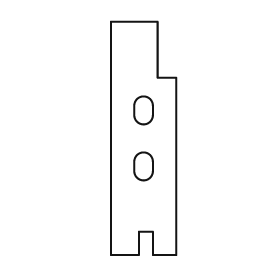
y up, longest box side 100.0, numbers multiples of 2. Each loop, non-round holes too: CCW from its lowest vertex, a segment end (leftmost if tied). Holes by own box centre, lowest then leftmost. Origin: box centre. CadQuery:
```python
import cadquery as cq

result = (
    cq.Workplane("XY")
    .moveTo(-14.0, -50.0)
    .lineTo(-2.0, -50.0)
    .lineTo(-2.0, -40.0)
    .lineTo(4.0, -40.0)
    .lineTo(4.0, -50.0)
    .lineTo(14.0, -50.0)
    .lineTo(14.0, 26.0)
    .lineTo(6.0, 26.0)
    .lineTo(6.0, 50.0)
    .lineTo(-14.0, 50.0)
    .close()
    .moveTo(-4.0, -14.0)
    .threePointArc((0.0, -18.0), (4.0, -14.0))
    .lineTo(4.0, -10.0)
    .threePointArc((0.0, -6.0), (-4.0, -10.0))
    .close()
    .moveTo(-4.0, 10.0)
    .threePointArc((0.0, 6.0), (4.0, 10.0))
    .lineTo(4.0, 14.0)
    .threePointArc((0.0, 18.0), (-4.0, 14.0))
    .close()
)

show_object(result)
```